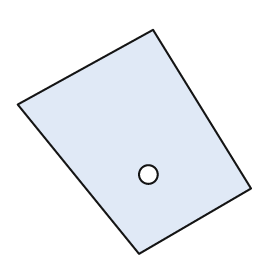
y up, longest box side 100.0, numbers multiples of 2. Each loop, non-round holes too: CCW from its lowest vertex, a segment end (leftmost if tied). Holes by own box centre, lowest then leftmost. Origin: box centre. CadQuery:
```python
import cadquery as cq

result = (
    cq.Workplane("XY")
    .moveTo(2.0, -48.0)
    .lineTo(50.0, -20.0)
    .lineTo(8.0, 48.0)
    .lineTo(-50.0, 16.0)
    .close()
    .moveTo(6.0, -14.0)
    .circle(4.0)
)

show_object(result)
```